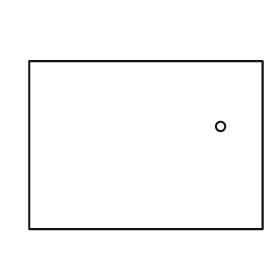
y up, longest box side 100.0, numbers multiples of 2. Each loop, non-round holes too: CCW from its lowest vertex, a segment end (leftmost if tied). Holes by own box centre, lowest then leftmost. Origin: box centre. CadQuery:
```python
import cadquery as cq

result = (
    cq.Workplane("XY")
    .moveTo(-50.0, -36.0)
    .lineTo(50.0, -36.0)
    .lineTo(50.0, 36.0)
    .lineTo(-50.0, 36.0)
    .close()
    .moveTo(32.0, 8.0)
    .circle(2.0)
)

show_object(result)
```